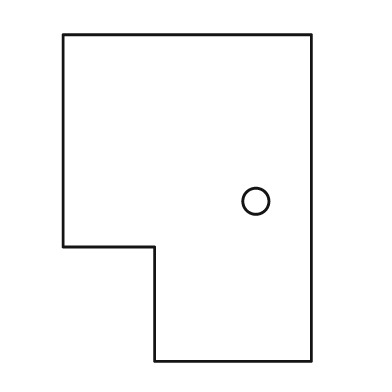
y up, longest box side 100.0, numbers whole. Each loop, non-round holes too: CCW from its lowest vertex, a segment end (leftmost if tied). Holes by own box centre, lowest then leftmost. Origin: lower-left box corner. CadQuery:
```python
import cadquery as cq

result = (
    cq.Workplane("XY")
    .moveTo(28.0, 0.0)
    .lineTo(76.0, 0.0)
    .lineTo(76.0, 100.0)
    .lineTo(0.0, 100.0)
    .lineTo(0.0, 35.0)
    .lineTo(28.0, 35.0)
    .close()
    .moveTo(59.0, 49.0)
    .circle(4.0)
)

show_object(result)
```